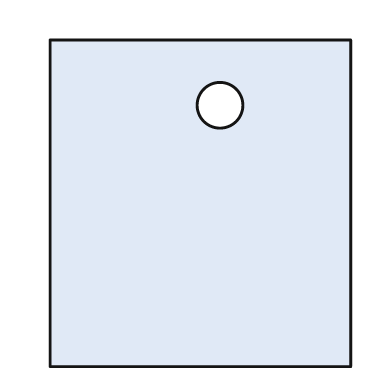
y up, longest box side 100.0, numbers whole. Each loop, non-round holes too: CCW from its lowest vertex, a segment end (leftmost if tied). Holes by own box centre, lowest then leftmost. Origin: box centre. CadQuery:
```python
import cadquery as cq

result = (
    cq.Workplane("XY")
    .moveTo(-46.0, -50.0)
    .lineTo(46.0, -50.0)
    .lineTo(46.0, 50.0)
    .lineTo(-46.0, 50.0)
    .close()
    .moveTo(6.0, 30.0)
    .circle(7.0)
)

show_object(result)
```